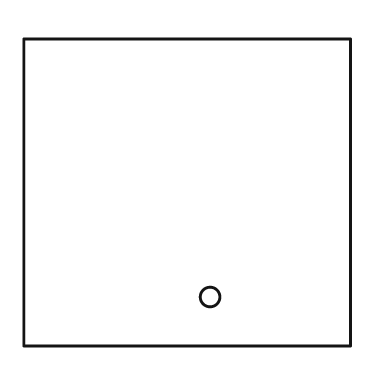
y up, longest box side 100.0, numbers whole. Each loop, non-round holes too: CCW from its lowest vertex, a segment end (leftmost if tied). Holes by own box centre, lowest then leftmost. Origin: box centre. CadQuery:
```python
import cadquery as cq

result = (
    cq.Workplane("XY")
    .moveTo(-50.0, -47.0)
    .lineTo(50.0, -47.0)
    .lineTo(50.0, 47.0)
    .lineTo(-50.0, 47.0)
    .close()
    .moveTo(7.0, -32.0)
    .circle(3.0)
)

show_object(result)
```